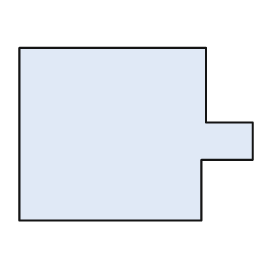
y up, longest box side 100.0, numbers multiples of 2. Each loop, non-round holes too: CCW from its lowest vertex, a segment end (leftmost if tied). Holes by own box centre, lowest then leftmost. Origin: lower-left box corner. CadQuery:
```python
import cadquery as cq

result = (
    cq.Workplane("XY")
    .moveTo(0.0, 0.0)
    .lineTo(78.0, 0.0)
    .lineTo(78.0, 26.0)
    .lineTo(100.0, 26.0)
    .lineTo(100.0, 42.0)
    .lineTo(80.0, 42.0)
    .lineTo(80.0, 74.0)
    .lineTo(0.0, 74.0)
    .close()
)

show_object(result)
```